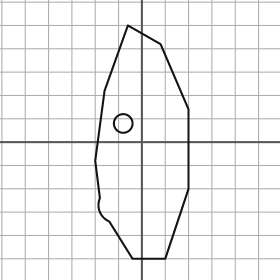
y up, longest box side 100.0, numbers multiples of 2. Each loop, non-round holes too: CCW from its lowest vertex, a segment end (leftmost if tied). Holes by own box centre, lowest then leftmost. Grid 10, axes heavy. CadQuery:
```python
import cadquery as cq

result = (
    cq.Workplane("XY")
    .moveTo(-4.0, -50.0)
    .lineTo(10.0, -50.0)
    .lineTo(20.0, -20.0)
    .lineTo(20.0, 14.0)
    .lineTo(8.0, 42.0)
    .lineTo(-6.0, 50.0)
    .lineTo(-16.0, 22.0)
    .lineTo(-20.0, -8.0)
    .lineTo(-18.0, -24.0)
    .threePointArc((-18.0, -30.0), (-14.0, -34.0))
    .close()
    .moveTo(-8.0, 8.0)
    .circle(4.0)
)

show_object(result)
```